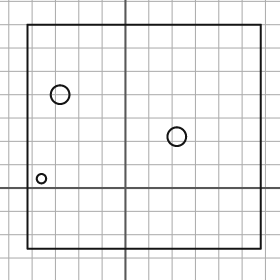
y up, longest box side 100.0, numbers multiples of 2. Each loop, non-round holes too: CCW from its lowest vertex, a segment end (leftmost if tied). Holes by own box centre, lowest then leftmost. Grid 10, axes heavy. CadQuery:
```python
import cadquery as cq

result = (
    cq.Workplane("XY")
    .moveTo(-42.0, -26.0)
    .lineTo(58.0, -26.0)
    .lineTo(58.0, 70.0)
    .lineTo(-42.0, 70.0)
    .close()
    .moveTo(-36.0, 4.0)
    .circle(2.0)
    .moveTo(22.0, 22.0)
    .circle(4.0)
    .moveTo(-28.0, 40.0)
    .circle(4.0)
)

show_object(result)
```